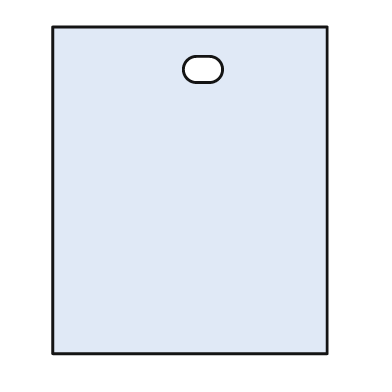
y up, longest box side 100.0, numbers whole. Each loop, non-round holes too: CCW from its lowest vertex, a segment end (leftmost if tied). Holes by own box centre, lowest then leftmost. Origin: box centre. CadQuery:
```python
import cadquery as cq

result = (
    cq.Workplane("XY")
    .moveTo(-42.0, -50.0)
    .lineTo(42.0, -50.0)
    .lineTo(42.0, 50.0)
    .lineTo(-42.0, 50.0)
    .close()
    .moveTo(2.0, 33.0)
    .lineTo(6.0, 33.0)
    .threePointArc((10.0, 37.0), (6.0, 41.0))
    .lineTo(2.0, 41.0)
    .threePointArc((-2.0, 37.0), (2.0, 33.0))
    .close()
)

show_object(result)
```